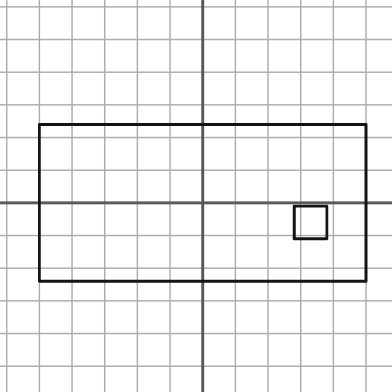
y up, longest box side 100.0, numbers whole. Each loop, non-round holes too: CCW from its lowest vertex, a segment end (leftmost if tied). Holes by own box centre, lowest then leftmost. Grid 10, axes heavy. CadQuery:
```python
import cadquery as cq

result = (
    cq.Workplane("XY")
    .moveTo(-50.0, -24.0)
    .lineTo(50.0, -24.0)
    .lineTo(50.0, 24.0)
    .lineTo(-50.0, 24.0)
    .close()
    .moveTo(28.0, -11.0)
    .lineTo(38.0, -11.0)
    .lineTo(38.0, -1.0)
    .lineTo(28.0, -1.0)
    .close()
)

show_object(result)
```